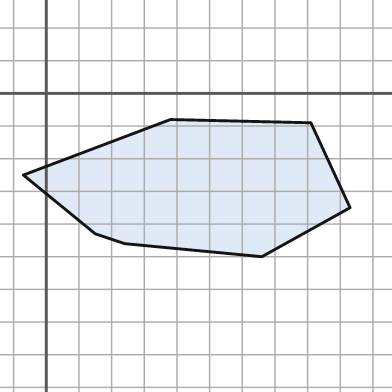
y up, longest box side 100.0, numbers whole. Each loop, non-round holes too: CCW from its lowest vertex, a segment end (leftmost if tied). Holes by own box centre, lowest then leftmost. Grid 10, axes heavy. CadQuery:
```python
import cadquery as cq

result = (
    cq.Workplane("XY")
    .moveTo(66.0, -50.0)
    .lineTo(93.0, -35.0)
    .lineTo(81.0, -9.0)
    .lineTo(38.0, -8.0)
    .lineTo(-7.0, -25.0)
    .lineTo(15.0, -43.0)
    .lineTo(24.0, -46.0)
    .close()
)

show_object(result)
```